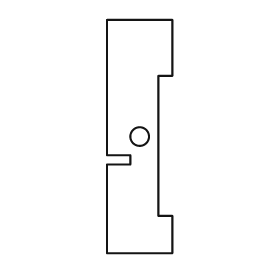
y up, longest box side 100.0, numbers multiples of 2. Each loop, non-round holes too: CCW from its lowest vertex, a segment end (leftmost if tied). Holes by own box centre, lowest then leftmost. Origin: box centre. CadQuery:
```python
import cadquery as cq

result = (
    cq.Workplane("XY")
    .moveTo(-14.0, -50.0)
    .lineTo(14.0, -50.0)
    .lineTo(14.0, -34.0)
    .lineTo(8.0, -34.0)
    .lineTo(8.0, 26.0)
    .lineTo(14.0, 26.0)
    .lineTo(14.0, 50.0)
    .lineTo(-14.0, 50.0)
    .lineTo(-14.0, -8.0)
    .lineTo(-4.0, -8.0)
    .lineTo(-4.0, -12.0)
    .lineTo(-14.0, -12.0)
    .close()
    .moveTo(0.0, 0.0)
    .circle(4.0)
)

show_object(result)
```